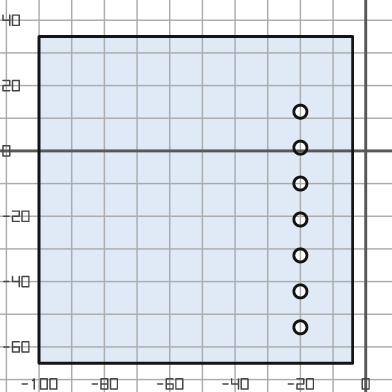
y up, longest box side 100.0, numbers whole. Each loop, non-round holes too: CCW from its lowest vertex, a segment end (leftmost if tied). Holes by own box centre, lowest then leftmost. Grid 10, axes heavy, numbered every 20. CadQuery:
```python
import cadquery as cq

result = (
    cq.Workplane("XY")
    .moveTo(-100.0, -65.0)
    .lineTo(-4.0, -65.0)
    .lineTo(-4.0, 35.0)
    .lineTo(-100.0, 35.0)
    .close()
    .moveTo(-20.0, -54.0)
    .circle(2.0)
    .moveTo(-20.0, -43.0)
    .circle(2.0)
    .moveTo(-20.0, -32.0)
    .circle(2.0)
    .moveTo(-20.0, -21.0)
    .circle(2.0)
    .moveTo(-20.0, -10.0)
    .circle(2.0)
    .moveTo(-20.0, 1.0)
    .circle(2.0)
    .moveTo(-20.0, 12.0)
    .circle(2.0)
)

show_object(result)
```